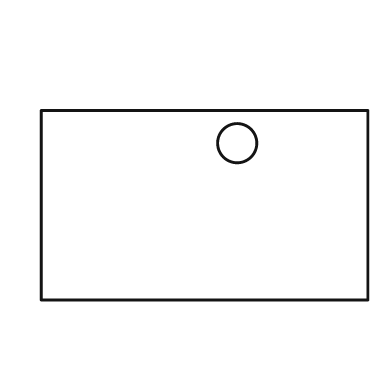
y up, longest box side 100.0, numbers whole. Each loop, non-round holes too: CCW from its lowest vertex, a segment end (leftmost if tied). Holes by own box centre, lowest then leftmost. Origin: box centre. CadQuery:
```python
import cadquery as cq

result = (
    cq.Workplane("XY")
    .moveTo(-50.0, -29.0)
    .lineTo(50.0, -29.0)
    .lineTo(50.0, 29.0)
    .lineTo(-50.0, 29.0)
    .close()
    .moveTo(10.0, 19.0)
    .circle(6.0)
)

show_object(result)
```